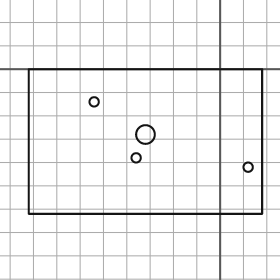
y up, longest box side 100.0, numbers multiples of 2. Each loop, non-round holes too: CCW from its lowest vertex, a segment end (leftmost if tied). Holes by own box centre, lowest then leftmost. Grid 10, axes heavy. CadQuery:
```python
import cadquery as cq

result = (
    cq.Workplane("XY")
    .moveTo(-82.0, -62.0)
    .lineTo(18.0, -62.0)
    .lineTo(18.0, 0.0)
    .lineTo(-82.0, 0.0)
    .close()
    .moveTo(12.0, -42.0)
    .circle(2.0)
    .moveTo(-36.0, -38.0)
    .circle(2.0)
    .moveTo(-32.0, -28.0)
    .circle(4.0)
    .moveTo(-54.0, -14.0)
    .circle(2.0)
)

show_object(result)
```